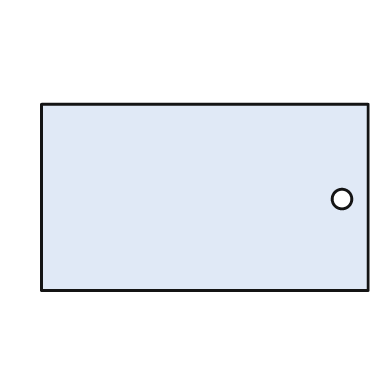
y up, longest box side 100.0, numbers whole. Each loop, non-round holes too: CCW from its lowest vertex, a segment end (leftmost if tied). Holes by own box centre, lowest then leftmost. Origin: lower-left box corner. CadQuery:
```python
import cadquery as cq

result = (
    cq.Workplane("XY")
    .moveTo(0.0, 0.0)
    .lineTo(100.0, 0.0)
    .lineTo(100.0, 57.0)
    .lineTo(0.0, 57.0)
    .close()
    .moveTo(92.0, 28.0)
    .circle(3.0)
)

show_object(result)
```